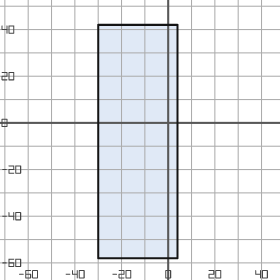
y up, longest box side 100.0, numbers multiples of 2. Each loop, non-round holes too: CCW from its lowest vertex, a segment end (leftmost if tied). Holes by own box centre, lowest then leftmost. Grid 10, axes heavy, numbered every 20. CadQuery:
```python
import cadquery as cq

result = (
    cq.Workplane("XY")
    .moveTo(-30.0, -58.0)
    .lineTo(4.0, -58.0)
    .lineTo(4.0, 42.0)
    .lineTo(-30.0, 42.0)
    .close()
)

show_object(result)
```